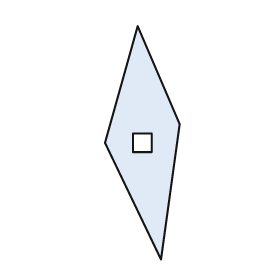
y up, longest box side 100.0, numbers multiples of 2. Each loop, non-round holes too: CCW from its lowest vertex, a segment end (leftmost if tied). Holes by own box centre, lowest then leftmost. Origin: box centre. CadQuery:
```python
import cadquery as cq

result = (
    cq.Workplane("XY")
    .moveTo(8.0, -50.0)
    .lineTo(16.0, 8.0)
    .lineTo(-2.0, 50.0)
    .lineTo(-16.0, 0.0)
    .close()
    .moveTo(-4.0, -4.0)
    .lineTo(4.0, -4.0)
    .lineTo(4.0, 4.0)
    .lineTo(-4.0, 4.0)
    .close()
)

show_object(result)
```